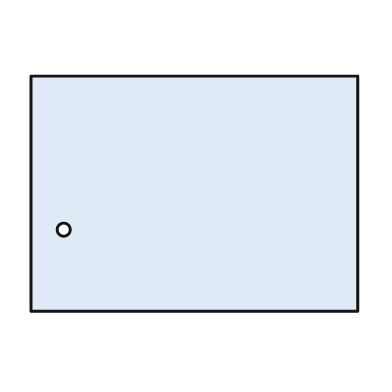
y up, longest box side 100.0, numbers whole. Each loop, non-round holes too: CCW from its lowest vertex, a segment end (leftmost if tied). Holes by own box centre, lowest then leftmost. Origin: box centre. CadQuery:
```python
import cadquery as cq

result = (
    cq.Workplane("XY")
    .moveTo(-50.0, -36.0)
    .lineTo(50.0, -36.0)
    .lineTo(50.0, 36.0)
    .lineTo(-50.0, 36.0)
    .close()
    .moveTo(-40.0, -11.0)
    .circle(2.0)
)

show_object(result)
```